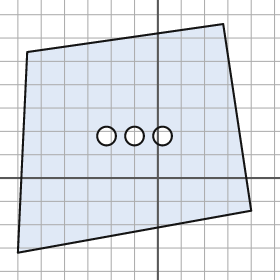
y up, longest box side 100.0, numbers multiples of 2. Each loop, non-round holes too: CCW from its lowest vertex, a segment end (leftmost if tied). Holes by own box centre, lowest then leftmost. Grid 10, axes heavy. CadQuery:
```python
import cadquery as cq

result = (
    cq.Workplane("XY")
    .moveTo(-60.0, -32.0)
    .lineTo(40.0, -14.0)
    .lineTo(28.0, 66.0)
    .lineTo(-56.0, 54.0)
    .close()
    .moveTo(-22.0, 18.0)
    .circle(4.0)
    .moveTo(-10.0, 18.0)
    .circle(4.0)
    .moveTo(2.0, 18.0)
    .circle(4.0)
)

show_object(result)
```